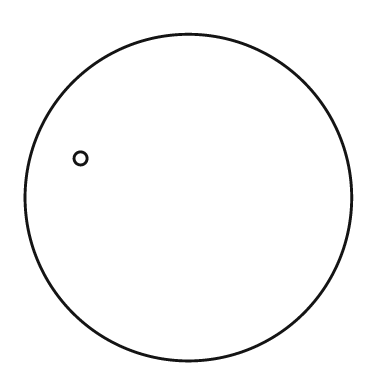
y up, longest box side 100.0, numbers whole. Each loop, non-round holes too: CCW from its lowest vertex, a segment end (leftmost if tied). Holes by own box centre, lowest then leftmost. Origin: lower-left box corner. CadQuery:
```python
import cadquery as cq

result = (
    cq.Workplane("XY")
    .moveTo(50.0, 50.0)
    .circle(50.0)
    .moveTo(17.0, 62.0)
    .circle(2.0)
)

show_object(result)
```